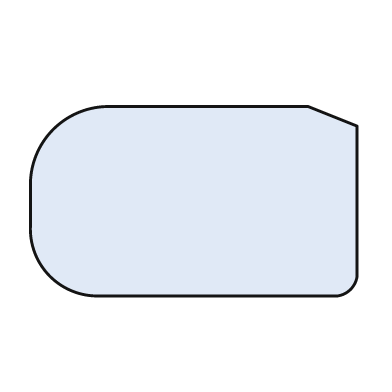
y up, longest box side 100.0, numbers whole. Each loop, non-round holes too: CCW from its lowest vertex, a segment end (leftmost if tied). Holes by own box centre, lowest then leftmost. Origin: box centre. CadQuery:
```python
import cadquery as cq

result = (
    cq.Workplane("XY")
    .moveTo(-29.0, -29.0)
    .lineTo(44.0, -29.0)
    .threePointArc((48.0, -27.0), (50.0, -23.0))
    .lineTo(50.0, 23.0)
    .lineTo(35.0, 29.0)
    .lineTo(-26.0, 29.0)
    .threePointArc((-43.0, 22.0), (-50.0, 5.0))
    .lineTo(-50.0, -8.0)
    .threePointArc((-44.0, -23.0), (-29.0, -29.0))
    .close()
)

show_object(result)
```